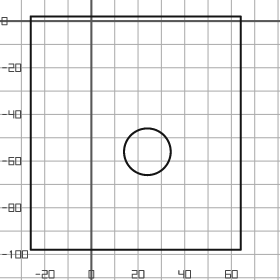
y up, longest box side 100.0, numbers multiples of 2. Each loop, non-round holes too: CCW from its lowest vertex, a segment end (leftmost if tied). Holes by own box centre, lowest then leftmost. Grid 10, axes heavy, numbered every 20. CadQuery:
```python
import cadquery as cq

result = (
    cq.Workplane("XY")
    .moveTo(-26.0, -98.0)
    .lineTo(64.0, -98.0)
    .lineTo(64.0, 2.0)
    .lineTo(-26.0, 2.0)
    .close()
    .moveTo(24.0, -56.0)
    .circle(10.0)
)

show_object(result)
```